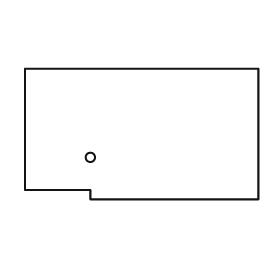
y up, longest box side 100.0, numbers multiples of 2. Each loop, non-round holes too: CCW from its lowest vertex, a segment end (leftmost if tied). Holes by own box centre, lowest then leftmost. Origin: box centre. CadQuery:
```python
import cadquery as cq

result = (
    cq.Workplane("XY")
    .moveTo(-22.0, -28.0)
    .lineTo(50.0, -28.0)
    .lineTo(50.0, 28.0)
    .lineTo(-50.0, 28.0)
    .lineTo(-50.0, -24.0)
    .lineTo(-22.0, -24.0)
    .close()
    .moveTo(-22.0, -10.0)
    .circle(2.0)
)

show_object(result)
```